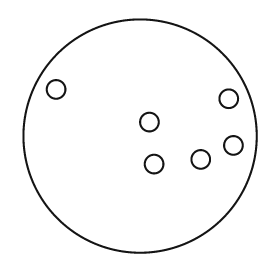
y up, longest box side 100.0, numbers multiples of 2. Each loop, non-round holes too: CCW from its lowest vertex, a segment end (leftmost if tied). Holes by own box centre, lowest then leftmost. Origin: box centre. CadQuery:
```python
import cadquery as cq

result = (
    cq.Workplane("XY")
    .moveTo(0.0, 0.0)
    .circle(50.0)
    .moveTo(6.0, -12.0)
    .circle(4.0)
    .moveTo(26.0, -10.0)
    .circle(4.0)
    .moveTo(40.0, -4.0)
    .circle(4.0)
    .moveTo(4.0, 6.0)
    .circle(4.0)
    .moveTo(38.0, 16.0)
    .circle(4.0)
    .moveTo(-36.0, 20.0)
    .circle(4.0)
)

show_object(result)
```